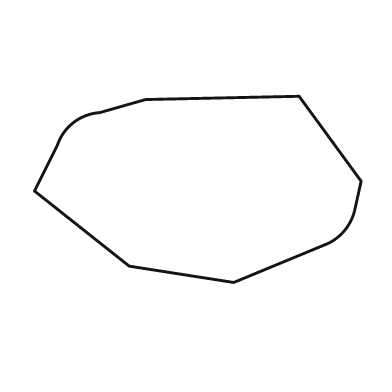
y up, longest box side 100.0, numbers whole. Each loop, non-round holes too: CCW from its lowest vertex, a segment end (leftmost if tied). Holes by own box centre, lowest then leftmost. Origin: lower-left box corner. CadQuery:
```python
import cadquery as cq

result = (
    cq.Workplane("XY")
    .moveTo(61.0, 0.0)
    .lineTo(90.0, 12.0)
    .threePointArc((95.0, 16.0), (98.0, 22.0))
    .lineTo(100.0, 31.0)
    .lineTo(81.0, 57.0)
    .lineTo(34.0, 56.0)
    .lineTo(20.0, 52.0)
    .threePointArc((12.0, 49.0), (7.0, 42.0))
    .lineTo(0.0, 28.0)
    .lineTo(29.0, 5.0)
    .close()
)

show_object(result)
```